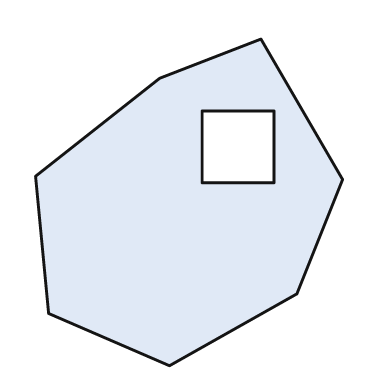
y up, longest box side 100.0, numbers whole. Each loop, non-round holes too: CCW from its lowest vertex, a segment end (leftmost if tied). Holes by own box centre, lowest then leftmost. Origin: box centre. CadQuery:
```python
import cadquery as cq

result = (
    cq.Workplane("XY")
    .moveTo(-6.0, -50.0)
    .lineTo(33.0, -28.0)
    .lineTo(47.0, 7.0)
    .lineTo(22.0, 50.0)
    .lineTo(-9.0, 38.0)
    .lineTo(-47.0, 8.0)
    .lineTo(-43.0, -34.0)
    .close()
    .moveTo(4.0, 6.0)
    .lineTo(26.0, 6.0)
    .lineTo(26.0, 28.0)
    .lineTo(4.0, 28.0)
    .close()
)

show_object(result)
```